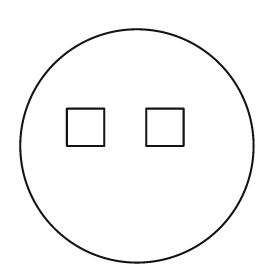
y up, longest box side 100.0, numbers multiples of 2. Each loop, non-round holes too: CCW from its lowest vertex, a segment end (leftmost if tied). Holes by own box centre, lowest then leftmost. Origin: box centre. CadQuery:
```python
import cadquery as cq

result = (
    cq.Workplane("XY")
    .moveTo(0.0, 0.0)
    .circle(50.0)
    .moveTo(-30.0, 0.0)
    .lineTo(-14.0, 0.0)
    .lineTo(-14.0, 16.0)
    .lineTo(-30.0, 16.0)
    .close()
    .moveTo(4.0, 0.0)
    .lineTo(20.0, 0.0)
    .lineTo(20.0, 16.0)
    .lineTo(4.0, 16.0)
    .close()
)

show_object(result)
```